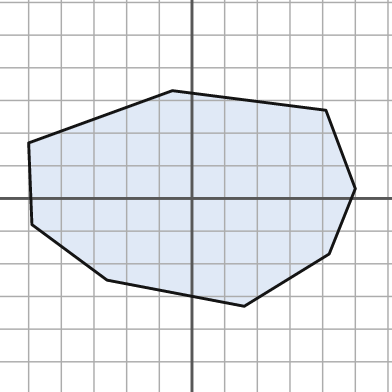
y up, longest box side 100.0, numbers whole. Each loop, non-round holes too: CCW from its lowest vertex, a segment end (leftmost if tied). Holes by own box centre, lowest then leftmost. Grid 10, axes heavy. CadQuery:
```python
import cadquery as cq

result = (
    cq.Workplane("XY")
    .moveTo(16.0, -33.0)
    .lineTo(42.0, -17.0)
    .lineTo(50.0, 3.0)
    .lineTo(41.0, 27.0)
    .lineTo(-6.0, 33.0)
    .lineTo(-50.0, 17.0)
    .lineTo(-49.0, -8.0)
    .lineTo(-26.0, -25.0)
    .close()
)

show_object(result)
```